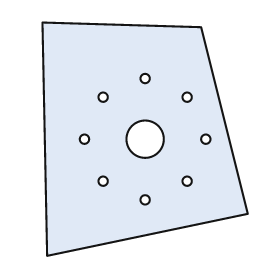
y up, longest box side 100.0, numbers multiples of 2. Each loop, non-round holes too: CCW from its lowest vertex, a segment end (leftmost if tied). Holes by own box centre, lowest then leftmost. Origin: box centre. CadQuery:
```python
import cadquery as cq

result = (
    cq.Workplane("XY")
    .moveTo(-42.0, -50.0)
    .lineTo(44.0, -32.0)
    .lineTo(24.0, 48.0)
    .lineTo(-44.0, 50.0)
    .close()
    .moveTo(0.0, -26.0)
    .circle(2.0)
    .moveTo(-18.0, -18.0)
    .circle(2.0)
    .moveTo(18.0, -18.0)
    .circle(2.0)
    .moveTo(-26.0, 0.0)
    .circle(2.0)
    .moveTo(0.0, 0.0)
    .circle(8.0)
    .moveTo(26.0, 0.0)
    .circle(2.0)
    .moveTo(-18.0, 18.0)
    .circle(2.0)
    .moveTo(18.0, 18.0)
    .circle(2.0)
    .moveTo(0.0, 26.0)
    .circle(2.0)
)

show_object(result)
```